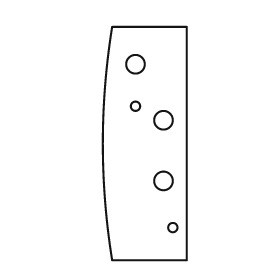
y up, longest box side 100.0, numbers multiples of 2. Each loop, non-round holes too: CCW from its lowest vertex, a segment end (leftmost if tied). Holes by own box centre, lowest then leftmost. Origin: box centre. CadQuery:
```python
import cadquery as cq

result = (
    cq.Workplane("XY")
    .moveTo(-14.0, -50.0)
    .lineTo(18.0, -50.0)
    .lineTo(18.0, 50.0)
    .lineTo(-14.0, 50.0)
    .threePointArc((-18.0, 0.0), (-14.0, -50.0))
    .close()
    .moveTo(12.0, -36.0)
    .circle(2.0)
    .moveTo(8.0, -16.0)
    .circle(4.0)
    .moveTo(8.0, 10.0)
    .circle(4.0)
    .moveTo(-4.0, 16.0)
    .circle(2.0)
    .moveTo(-4.0, 34.0)
    .circle(4.0)
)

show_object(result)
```